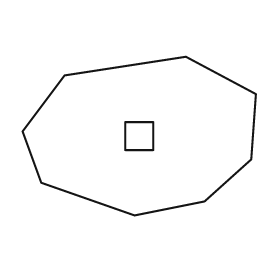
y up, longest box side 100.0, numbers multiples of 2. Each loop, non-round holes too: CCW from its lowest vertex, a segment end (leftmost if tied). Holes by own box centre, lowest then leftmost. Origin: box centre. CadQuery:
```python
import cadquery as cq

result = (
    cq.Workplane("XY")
    .moveTo(-2.0, -34.0)
    .lineTo(28.0, -28.0)
    .lineTo(48.0, -10.0)
    .lineTo(50.0, 18.0)
    .lineTo(20.0, 34.0)
    .lineTo(-32.0, 26.0)
    .lineTo(-50.0, 2.0)
    .lineTo(-42.0, -20.0)
    .close()
    .moveTo(-6.0, -6.0)
    .lineTo(6.0, -6.0)
    .lineTo(6.0, 6.0)
    .lineTo(-6.0, 6.0)
    .close()
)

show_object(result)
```